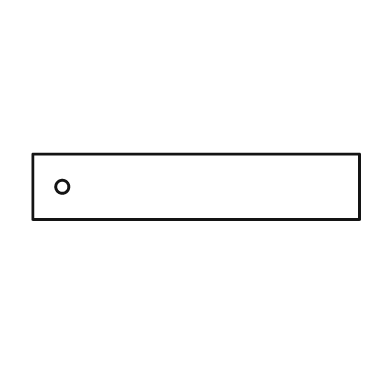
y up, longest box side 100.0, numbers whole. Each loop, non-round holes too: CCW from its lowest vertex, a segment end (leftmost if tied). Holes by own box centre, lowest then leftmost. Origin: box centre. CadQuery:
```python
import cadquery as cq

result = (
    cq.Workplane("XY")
    .moveTo(-50.0, -10.0)
    .lineTo(50.0, -10.0)
    .lineTo(50.0, 10.0)
    .lineTo(-50.0, 10.0)
    .close()
    .moveTo(-41.0, 0.0)
    .circle(2.0)
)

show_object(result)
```